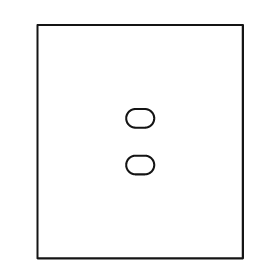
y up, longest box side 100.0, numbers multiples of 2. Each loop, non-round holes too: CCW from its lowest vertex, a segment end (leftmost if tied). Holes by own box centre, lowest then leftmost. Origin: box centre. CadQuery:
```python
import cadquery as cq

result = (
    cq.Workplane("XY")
    .moveTo(-44.0, -50.0)
    .lineTo(44.0, -50.0)
    .lineTo(44.0, 50.0)
    .lineTo(-44.0, 50.0)
    .close()
    .moveTo(-2.0, -14.0)
    .lineTo(2.0, -14.0)
    .threePointArc((6.0, -10.0), (2.0, -6.0))
    .lineTo(-2.0, -6.0)
    .threePointArc((-6.0, -10.0), (-2.0, -14.0))
    .close()
    .moveTo(-2.0, 6.0)
    .lineTo(2.0, 6.0)
    .threePointArc((6.0, 10.0), (2.0, 14.0))
    .lineTo(-2.0, 14.0)
    .threePointArc((-6.0, 10.0), (-2.0, 6.0))
    .close()
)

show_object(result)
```